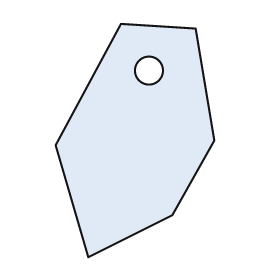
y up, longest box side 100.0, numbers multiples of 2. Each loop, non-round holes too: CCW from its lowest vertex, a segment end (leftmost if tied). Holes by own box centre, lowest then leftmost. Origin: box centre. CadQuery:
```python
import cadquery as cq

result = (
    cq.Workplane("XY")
    .moveTo(-20.0, -50.0)
    .lineTo(16.0, -32.0)
    .lineTo(34.0, 0.0)
    .lineTo(26.0, 48.0)
    .lineTo(-6.0, 50.0)
    .lineTo(-34.0, -2.0)
    .close()
    .moveTo(6.0, 30.0)
    .circle(6.0)
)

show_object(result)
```